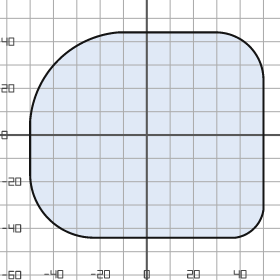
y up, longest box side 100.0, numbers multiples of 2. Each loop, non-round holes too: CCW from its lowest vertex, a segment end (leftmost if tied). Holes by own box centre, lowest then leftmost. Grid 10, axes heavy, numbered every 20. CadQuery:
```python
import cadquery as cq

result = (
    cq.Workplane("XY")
    .moveTo(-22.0, -44.0)
    .lineTo(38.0, -44.0)
    .threePointArc((46.0, -40.0), (50.0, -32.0))
    .lineTo(50.0, 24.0)
    .threePointArc((44.0, 38.0), (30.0, 44.0))
    .lineTo(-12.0, 44.0)
    .threePointArc((-38.0, 32.0), (-50.0, 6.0))
    .lineTo(-50.0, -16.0)
    .threePointArc((-42.0, -36.0), (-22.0, -44.0))
    .close()
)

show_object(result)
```